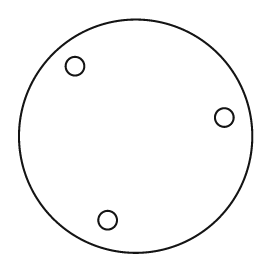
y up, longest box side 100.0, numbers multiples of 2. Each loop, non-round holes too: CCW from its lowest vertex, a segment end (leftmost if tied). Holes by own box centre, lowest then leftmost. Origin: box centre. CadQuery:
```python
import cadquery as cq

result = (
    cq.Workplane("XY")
    .moveTo(0.0, 0.0)
    .circle(50.0)
    .moveTo(-12.0, -36.0)
    .circle(4.0)
    .moveTo(38.0, 8.0)
    .circle(4.0)
    .moveTo(-26.0, 30.0)
    .circle(4.0)
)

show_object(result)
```